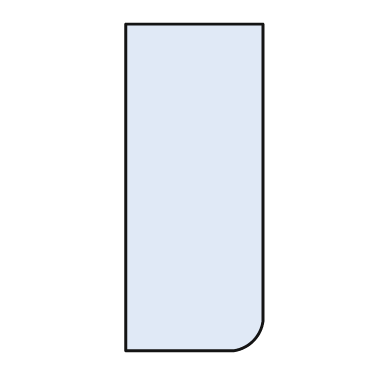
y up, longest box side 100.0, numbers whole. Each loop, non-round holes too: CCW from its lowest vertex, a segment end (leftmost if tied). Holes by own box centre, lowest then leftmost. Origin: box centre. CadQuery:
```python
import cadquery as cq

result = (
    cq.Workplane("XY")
    .moveTo(-21.0, -50.0)
    .lineTo(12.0, -50.0)
    .threePointArc((18.0, -47.0), (21.0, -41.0))
    .lineTo(21.0, 50.0)
    .lineTo(-21.0, 50.0)
    .close()
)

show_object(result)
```